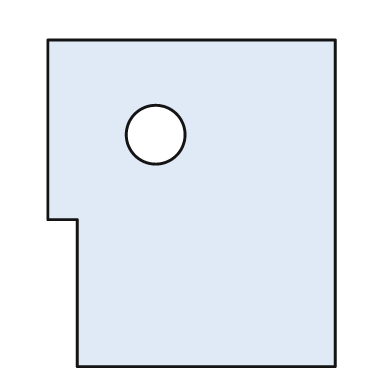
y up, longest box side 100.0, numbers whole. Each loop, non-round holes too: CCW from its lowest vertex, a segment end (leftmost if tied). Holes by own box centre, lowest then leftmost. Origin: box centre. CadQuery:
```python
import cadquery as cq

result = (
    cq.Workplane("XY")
    .moveTo(-35.0, -50.0)
    .lineTo(44.0, -50.0)
    .lineTo(44.0, 50.0)
    .lineTo(-44.0, 50.0)
    .lineTo(-44.0, -5.0)
    .lineTo(-35.0, -5.0)
    .close()
    .moveTo(-11.0, 21.0)
    .circle(9.0)
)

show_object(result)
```